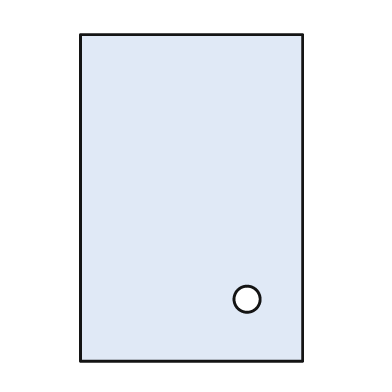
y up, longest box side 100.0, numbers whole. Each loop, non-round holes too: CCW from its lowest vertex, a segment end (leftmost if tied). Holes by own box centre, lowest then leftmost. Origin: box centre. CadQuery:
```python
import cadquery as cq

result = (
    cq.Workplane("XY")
    .moveTo(-34.0, -50.0)
    .lineTo(34.0, -50.0)
    .lineTo(34.0, 50.0)
    .lineTo(-34.0, 50.0)
    .close()
    .moveTo(17.0, -31.0)
    .circle(4.0)
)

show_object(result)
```